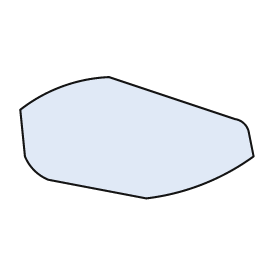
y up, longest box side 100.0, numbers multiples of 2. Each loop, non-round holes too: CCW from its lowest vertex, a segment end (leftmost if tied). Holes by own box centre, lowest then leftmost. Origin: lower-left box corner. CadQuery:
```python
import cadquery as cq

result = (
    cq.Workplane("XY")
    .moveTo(54.0, 0.0)
    .threePointArc((78.0, 6.0), (100.0, 18.0))
    .lineTo(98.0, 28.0)
    .threePointArc((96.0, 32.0), (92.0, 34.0))
    .lineTo(38.0, 52.0)
    .threePointArc((18.0, 48.0), (0.0, 38.0))
    .lineTo(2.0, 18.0)
    .threePointArc((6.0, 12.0), (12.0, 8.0))
    .close()
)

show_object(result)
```